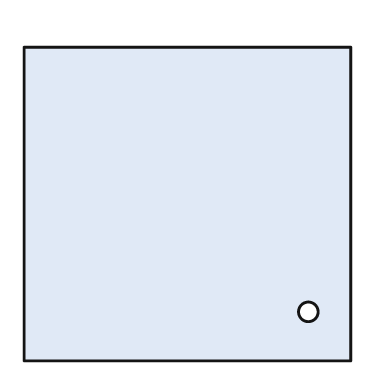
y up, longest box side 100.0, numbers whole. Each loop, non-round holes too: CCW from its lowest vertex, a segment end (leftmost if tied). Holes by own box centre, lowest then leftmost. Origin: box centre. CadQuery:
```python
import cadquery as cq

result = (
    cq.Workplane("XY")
    .moveTo(-50.0, -48.0)
    .lineTo(50.0, -48.0)
    .lineTo(50.0, 48.0)
    .lineTo(-50.0, 48.0)
    .close()
    .moveTo(37.0, -33.0)
    .circle(3.0)
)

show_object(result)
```